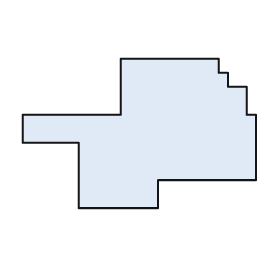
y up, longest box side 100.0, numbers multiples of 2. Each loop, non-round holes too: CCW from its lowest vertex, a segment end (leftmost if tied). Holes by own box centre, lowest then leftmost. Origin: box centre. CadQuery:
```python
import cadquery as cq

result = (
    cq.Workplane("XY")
    .moveTo(-26.0, -32.0)
    .lineTo(8.0, -32.0)
    .lineTo(8.0, -20.0)
    .lineTo(50.0, -20.0)
    .lineTo(50.0, 8.0)
    .lineTo(46.0, 8.0)
    .lineTo(46.0, 20.0)
    .lineTo(38.0, 20.0)
    .lineTo(38.0, 26.0)
    .lineTo(34.0, 26.0)
    .lineTo(34.0, 32.0)
    .lineTo(-8.0, 32.0)
    .lineTo(-8.0, 8.0)
    .lineTo(-50.0, 8.0)
    .lineTo(-50.0, -4.0)
    .lineTo(-26.0, -4.0)
    .close()
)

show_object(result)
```